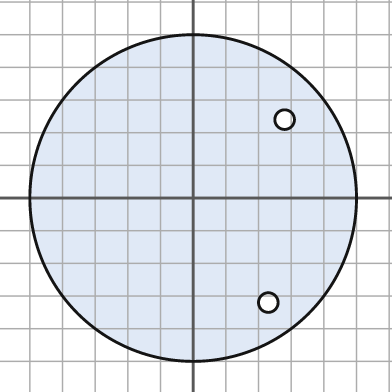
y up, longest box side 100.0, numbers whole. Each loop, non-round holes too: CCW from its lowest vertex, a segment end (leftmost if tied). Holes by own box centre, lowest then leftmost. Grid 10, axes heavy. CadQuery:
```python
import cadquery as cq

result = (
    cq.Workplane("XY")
    .moveTo(0.0, 0.0)
    .circle(50.0)
    .moveTo(23.0, -32.0)
    .circle(3.0)
    .moveTo(28.0, 24.0)
    .circle(3.0)
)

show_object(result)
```